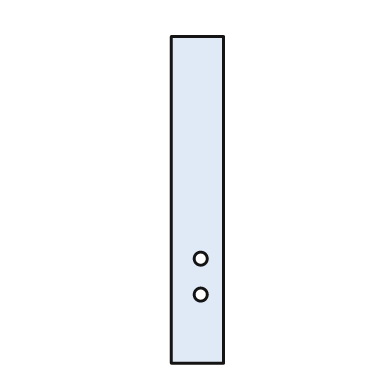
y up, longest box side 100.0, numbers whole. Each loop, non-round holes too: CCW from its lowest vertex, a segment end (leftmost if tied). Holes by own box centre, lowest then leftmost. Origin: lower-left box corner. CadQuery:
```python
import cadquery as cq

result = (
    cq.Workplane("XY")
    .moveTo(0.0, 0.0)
    .lineTo(16.0, 0.0)
    .lineTo(16.0, 100.0)
    .lineTo(0.0, 100.0)
    .close()
    .moveTo(9.0, 21.0)
    .circle(2.0)
    .moveTo(9.0, 32.0)
    .circle(2.0)
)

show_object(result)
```